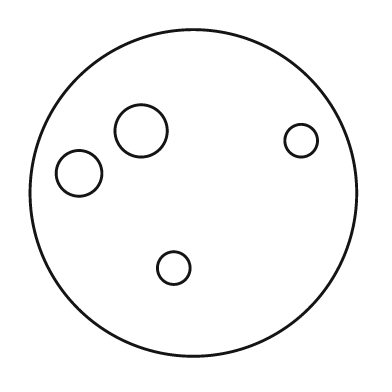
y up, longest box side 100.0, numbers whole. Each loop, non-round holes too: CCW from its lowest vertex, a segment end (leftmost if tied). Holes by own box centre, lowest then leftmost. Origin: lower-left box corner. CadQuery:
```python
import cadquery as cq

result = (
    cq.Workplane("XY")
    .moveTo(50.0, 50.0)
    .circle(50.0)
    .moveTo(44.0, 27.0)
    .circle(5.0)
    .moveTo(15.0, 56.0)
    .circle(7.0)
    .moveTo(83.0, 66.0)
    .circle(5.0)
    .moveTo(34.0, 69.0)
    .circle(8.0)
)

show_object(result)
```